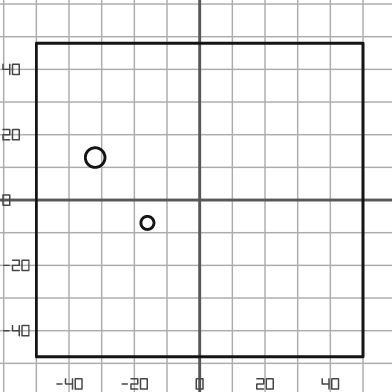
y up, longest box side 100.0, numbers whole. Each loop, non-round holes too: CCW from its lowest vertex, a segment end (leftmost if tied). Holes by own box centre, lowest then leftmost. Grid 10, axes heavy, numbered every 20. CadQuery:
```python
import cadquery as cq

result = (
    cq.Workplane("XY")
    .moveTo(-50.0, -48.0)
    .lineTo(50.0, -48.0)
    .lineTo(50.0, 48.0)
    .lineTo(-50.0, 48.0)
    .close()
    .moveTo(-16.0, -7.0)
    .circle(2.0)
    .moveTo(-32.0, 13.0)
    .circle(3.0)
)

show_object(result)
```